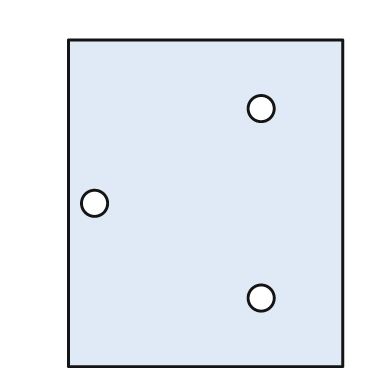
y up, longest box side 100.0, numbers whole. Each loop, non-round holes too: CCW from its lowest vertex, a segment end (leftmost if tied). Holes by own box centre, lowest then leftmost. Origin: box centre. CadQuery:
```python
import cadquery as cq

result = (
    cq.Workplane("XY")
    .moveTo(-42.0, -50.0)
    .lineTo(42.0, -50.0)
    .lineTo(42.0, 50.0)
    .lineTo(-42.0, 50.0)
    .close()
    .moveTo(17.0, -29.0)
    .circle(4.0)
    .moveTo(-34.0, 0.0)
    .circle(4.0)
    .moveTo(17.0, 29.0)
    .circle(4.0)
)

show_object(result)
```